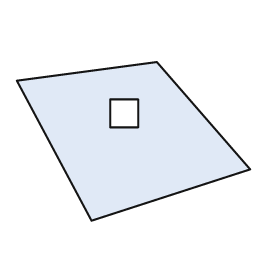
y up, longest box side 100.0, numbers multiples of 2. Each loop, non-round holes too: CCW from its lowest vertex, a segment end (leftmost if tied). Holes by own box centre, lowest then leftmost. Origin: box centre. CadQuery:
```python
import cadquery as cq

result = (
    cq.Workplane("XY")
    .moveTo(-18.0, -34.0)
    .lineTo(50.0, -12.0)
    .lineTo(10.0, 34.0)
    .lineTo(-50.0, 26.0)
    .close()
    .moveTo(-10.0, 6.0)
    .lineTo(2.0, 6.0)
    .lineTo(2.0, 18.0)
    .lineTo(-10.0, 18.0)
    .close()
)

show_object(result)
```